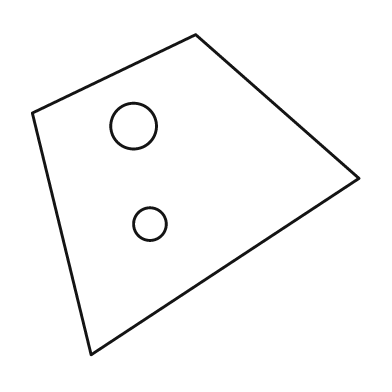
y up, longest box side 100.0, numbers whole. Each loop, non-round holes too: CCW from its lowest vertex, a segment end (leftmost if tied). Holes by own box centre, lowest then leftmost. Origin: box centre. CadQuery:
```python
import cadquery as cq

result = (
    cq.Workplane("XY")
    .moveTo(-32.0, -49.0)
    .lineTo(50.0, 5.0)
    .lineTo(0.0, 49.0)
    .lineTo(-50.0, 25.0)
    .close()
    .moveTo(-14.0, -9.0)
    .circle(5.0)
    .moveTo(-19.0, 21.0)
    .circle(7.0)
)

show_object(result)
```